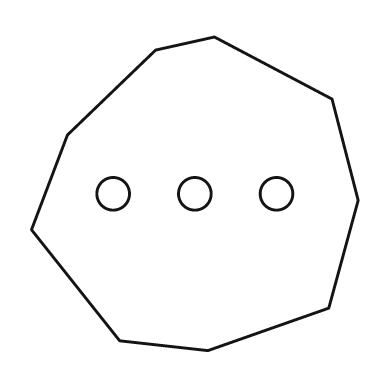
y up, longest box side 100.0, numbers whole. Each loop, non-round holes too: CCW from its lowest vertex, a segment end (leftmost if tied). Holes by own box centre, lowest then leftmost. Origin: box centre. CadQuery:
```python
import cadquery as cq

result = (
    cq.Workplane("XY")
    .moveTo(4.0, -48.0)
    .lineTo(41.0, -35.0)
    .lineTo(50.0, -2.0)
    .lineTo(42.0, 29.0)
    .lineTo(6.0, 48.0)
    .lineTo(-12.0, 44.0)
    .lineTo(-39.0, 18.0)
    .lineTo(-50.0, -11.0)
    .lineTo(-23.0, -45.0)
    .close()
    .moveTo(-25.0, 0.0)
    .circle(5.0)
    .moveTo(0.0, 0.0)
    .circle(5.0)
    .moveTo(25.0, 0.0)
    .circle(5.0)
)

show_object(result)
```